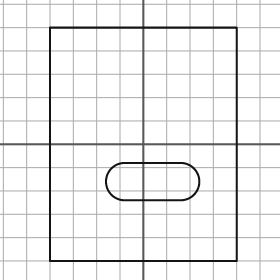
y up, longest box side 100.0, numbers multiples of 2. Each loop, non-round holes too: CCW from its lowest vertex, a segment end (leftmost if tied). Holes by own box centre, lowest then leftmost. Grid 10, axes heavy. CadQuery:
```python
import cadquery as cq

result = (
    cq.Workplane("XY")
    .moveTo(-40.0, -50.0)
    .lineTo(40.0, -50.0)
    .lineTo(40.0, 50.0)
    .lineTo(-40.0, 50.0)
    .close()
    .moveTo(-8.0, -24.0)
    .lineTo(16.0, -24.0)
    .threePointArc((24.0, -16.0), (16.0, -8.0))
    .lineTo(-8.0, -8.0)
    .threePointArc((-16.0, -16.0), (-8.0, -24.0))
    .close()
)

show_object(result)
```